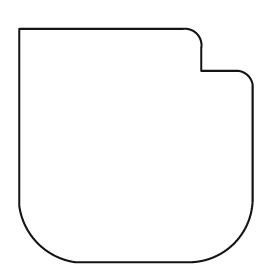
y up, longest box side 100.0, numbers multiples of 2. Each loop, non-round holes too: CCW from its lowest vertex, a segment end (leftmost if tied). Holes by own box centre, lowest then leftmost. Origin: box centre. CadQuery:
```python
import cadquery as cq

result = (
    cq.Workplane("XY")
    .moveTo(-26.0, -50.0)
    .lineTo(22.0, -50.0)
    .threePointArc((42.0, -42.0), (50.0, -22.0))
    .lineTo(50.0, 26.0)
    .threePointArc((48.0, 30.0), (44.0, 32.0))
    .lineTo(28.0, 32.0)
    .lineTo(28.0, 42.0)
    .threePointArc((26.0, 48.0), (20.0, 50.0))
    .lineTo(-50.0, 50.0)
    .lineTo(-50.0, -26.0)
    .threePointArc((-42.0, -42.0), (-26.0, -50.0))
    .close()
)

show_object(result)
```